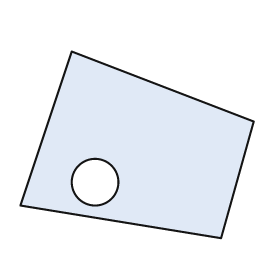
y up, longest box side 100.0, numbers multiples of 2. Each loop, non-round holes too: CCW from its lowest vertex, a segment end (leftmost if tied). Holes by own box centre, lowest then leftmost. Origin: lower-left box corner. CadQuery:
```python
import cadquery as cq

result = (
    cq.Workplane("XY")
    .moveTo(86.0, 0.0)
    .lineTo(100.0, 50.0)
    .lineTo(22.0, 80.0)
    .lineTo(0.0, 14.0)
    .close()
    .moveTo(32.0, 24.0)
    .circle(10.0)
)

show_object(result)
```